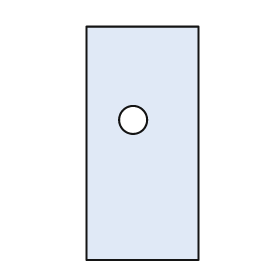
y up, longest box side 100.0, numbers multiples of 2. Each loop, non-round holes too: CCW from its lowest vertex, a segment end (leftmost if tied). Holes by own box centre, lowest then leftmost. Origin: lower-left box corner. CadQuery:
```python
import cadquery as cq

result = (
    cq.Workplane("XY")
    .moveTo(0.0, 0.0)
    .lineTo(48.0, 0.0)
    .lineTo(48.0, 100.0)
    .lineTo(0.0, 100.0)
    .close()
    .moveTo(20.0, 60.0)
    .circle(6.0)
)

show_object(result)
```